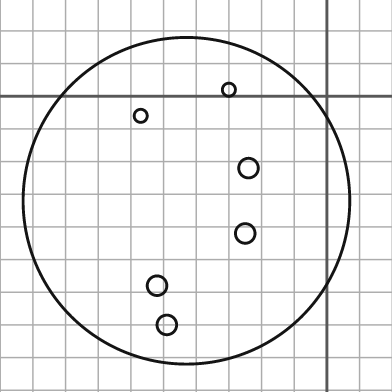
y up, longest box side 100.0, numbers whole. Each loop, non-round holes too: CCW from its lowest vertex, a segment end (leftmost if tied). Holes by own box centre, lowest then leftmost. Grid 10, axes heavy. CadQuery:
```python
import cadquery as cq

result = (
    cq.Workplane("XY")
    .moveTo(-43.0, -32.0)
    .circle(50.0)
    .moveTo(-49.0, -70.0)
    .circle(3.0)
    .moveTo(-52.0, -58.0)
    .circle(3.0)
    .moveTo(-25.0, -42.0)
    .circle(3.0)
    .moveTo(-24.0, -22.0)
    .circle(3.0)
    .moveTo(-57.0, -6.0)
    .circle(2.0)
    .moveTo(-30.0, 2.0)
    .circle(2.0)
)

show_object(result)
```